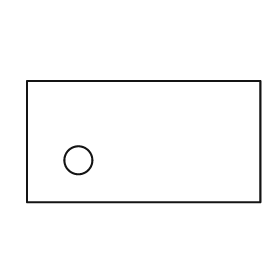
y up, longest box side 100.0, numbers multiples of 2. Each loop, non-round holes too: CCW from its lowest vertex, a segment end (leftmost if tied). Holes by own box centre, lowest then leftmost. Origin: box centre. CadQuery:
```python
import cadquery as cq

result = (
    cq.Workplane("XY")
    .moveTo(-50.0, -26.0)
    .lineTo(50.0, -26.0)
    .lineTo(50.0, 26.0)
    .lineTo(-50.0, 26.0)
    .close()
    .moveTo(-28.0, -8.0)
    .circle(6.0)
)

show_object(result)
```